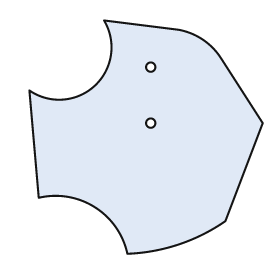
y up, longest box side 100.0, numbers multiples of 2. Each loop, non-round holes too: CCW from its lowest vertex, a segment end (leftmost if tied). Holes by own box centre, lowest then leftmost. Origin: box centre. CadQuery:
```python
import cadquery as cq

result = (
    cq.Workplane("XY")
    .moveTo(-8.0, -50.0)
    .threePointArc((14.0, -46.0), (34.0, -36.0))
    .lineTo(50.0, 6.0)
    .lineTo(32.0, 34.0)
    .threePointArc((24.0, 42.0), (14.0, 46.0))
    .lineTo(-18.0, 50.0)
    .threePointArc((-22.0, 22.0), (-50.0, 20.0))
    .lineTo(-46.0, -26.0)
    .threePointArc((-22.0, -30.0), (-8.0, -50.0))
    .close()
    .moveTo(2.0, 6.0)
    .circle(2.0)
    .moveTo(2.0, 30.0)
    .circle(2.0)
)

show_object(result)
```